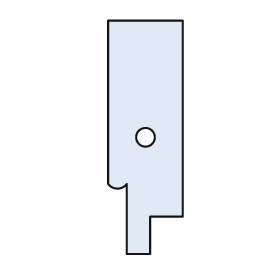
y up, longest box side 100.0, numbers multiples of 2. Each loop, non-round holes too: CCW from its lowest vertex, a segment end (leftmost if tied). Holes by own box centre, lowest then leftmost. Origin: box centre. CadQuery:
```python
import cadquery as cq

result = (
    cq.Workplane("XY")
    .moveTo(-8.0, -50.0)
    .lineTo(2.0, -50.0)
    .lineTo(2.0, -34.0)
    .lineTo(16.0, -34.0)
    .lineTo(16.0, 50.0)
    .lineTo(-16.0, 50.0)
    .lineTo(-16.0, -20.0)
    .threePointArc((-12.0, -22.0), (-8.0, -20.0))
    .close()
    .moveTo(0.0, 0.0)
    .circle(4.0)
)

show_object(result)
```